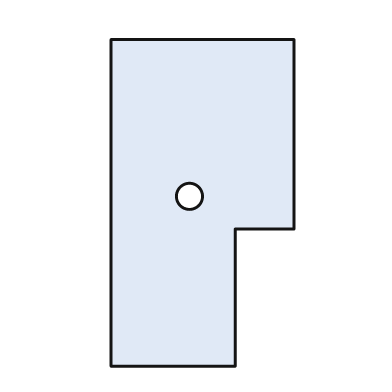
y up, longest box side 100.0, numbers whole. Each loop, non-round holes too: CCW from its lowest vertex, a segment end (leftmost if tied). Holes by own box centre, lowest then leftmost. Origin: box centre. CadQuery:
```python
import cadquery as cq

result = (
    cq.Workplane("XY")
    .moveTo(-28.0, -50.0)
    .lineTo(10.0, -50.0)
    .lineTo(10.0, -8.0)
    .lineTo(28.0, -8.0)
    .lineTo(28.0, 50.0)
    .lineTo(-28.0, 50.0)
    .close()
    .moveTo(-4.0, 2.0)
    .circle(4.0)
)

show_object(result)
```